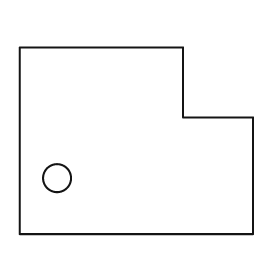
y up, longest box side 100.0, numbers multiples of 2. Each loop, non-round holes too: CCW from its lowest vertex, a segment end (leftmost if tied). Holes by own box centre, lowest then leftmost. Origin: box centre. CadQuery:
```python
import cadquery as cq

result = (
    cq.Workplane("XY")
    .moveTo(-50.0, -40.0)
    .lineTo(50.0, -40.0)
    .lineTo(50.0, 10.0)
    .lineTo(20.0, 10.0)
    .lineTo(20.0, 40.0)
    .lineTo(-50.0, 40.0)
    .close()
    .moveTo(-34.0, -16.0)
    .circle(6.0)
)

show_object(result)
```